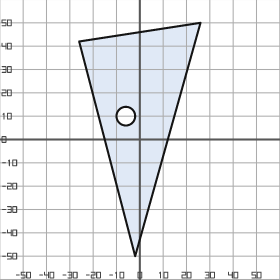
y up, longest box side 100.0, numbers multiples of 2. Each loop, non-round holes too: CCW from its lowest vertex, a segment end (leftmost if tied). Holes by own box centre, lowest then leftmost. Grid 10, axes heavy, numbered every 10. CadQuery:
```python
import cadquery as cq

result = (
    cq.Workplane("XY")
    .moveTo(-2.0, -50.0)
    .lineTo(26.0, 50.0)
    .lineTo(-26.0, 42.0)
    .close()
    .moveTo(-6.0, 10.0)
    .circle(4.0)
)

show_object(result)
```